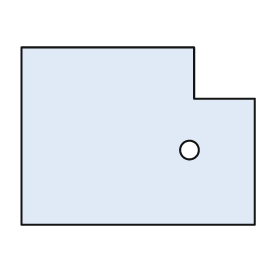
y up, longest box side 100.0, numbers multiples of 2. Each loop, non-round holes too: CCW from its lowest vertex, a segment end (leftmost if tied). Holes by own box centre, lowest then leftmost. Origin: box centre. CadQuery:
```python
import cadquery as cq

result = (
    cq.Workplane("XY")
    .moveTo(-50.0, -38.0)
    .lineTo(50.0, -38.0)
    .lineTo(50.0, 16.0)
    .lineTo(24.0, 16.0)
    .lineTo(24.0, 38.0)
    .lineTo(-50.0, 38.0)
    .close()
    .moveTo(22.0, -6.0)
    .circle(4.0)
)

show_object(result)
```